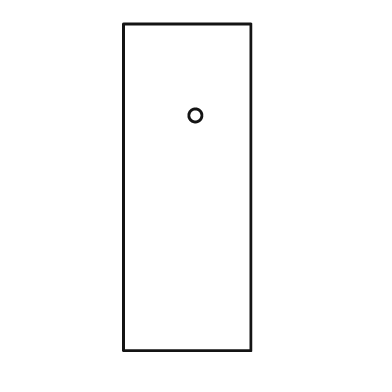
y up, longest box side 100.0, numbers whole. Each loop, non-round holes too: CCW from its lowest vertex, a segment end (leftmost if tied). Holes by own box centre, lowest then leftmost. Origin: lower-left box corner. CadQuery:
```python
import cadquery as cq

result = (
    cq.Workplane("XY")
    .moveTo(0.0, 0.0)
    .lineTo(39.0, 0.0)
    .lineTo(39.0, 100.0)
    .lineTo(0.0, 100.0)
    .close()
    .moveTo(22.0, 72.0)
    .circle(2.0)
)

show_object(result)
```